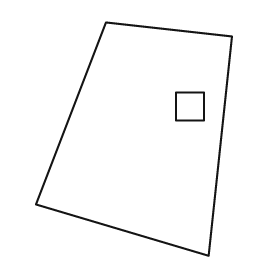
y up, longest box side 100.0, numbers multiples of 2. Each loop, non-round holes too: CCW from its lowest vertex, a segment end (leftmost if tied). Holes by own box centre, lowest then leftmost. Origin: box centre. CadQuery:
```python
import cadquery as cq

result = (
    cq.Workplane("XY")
    .moveTo(32.0, -50.0)
    .lineTo(42.0, 44.0)
    .lineTo(-12.0, 50.0)
    .lineTo(-42.0, -28.0)
    .close()
    .moveTo(18.0, 8.0)
    .lineTo(30.0, 8.0)
    .lineTo(30.0, 20.0)
    .lineTo(18.0, 20.0)
    .close()
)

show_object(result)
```